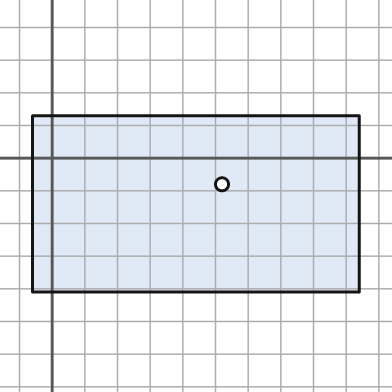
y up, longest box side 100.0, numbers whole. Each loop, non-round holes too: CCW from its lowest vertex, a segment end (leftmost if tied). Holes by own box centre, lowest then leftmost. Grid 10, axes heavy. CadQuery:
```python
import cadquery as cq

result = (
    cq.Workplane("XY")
    .moveTo(-6.0, -41.0)
    .lineTo(94.0, -41.0)
    .lineTo(94.0, 13.0)
    .lineTo(-6.0, 13.0)
    .close()
    .moveTo(52.0, -8.0)
    .circle(2.0)
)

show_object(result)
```